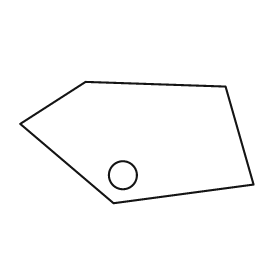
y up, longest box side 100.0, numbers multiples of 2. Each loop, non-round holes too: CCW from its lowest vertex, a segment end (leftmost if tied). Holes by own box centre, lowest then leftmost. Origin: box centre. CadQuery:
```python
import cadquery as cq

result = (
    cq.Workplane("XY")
    .moveTo(-10.0, -26.0)
    .lineTo(50.0, -18.0)
    .lineTo(38.0, 24.0)
    .lineTo(-22.0, 26.0)
    .lineTo(-50.0, 8.0)
    .close()
    .moveTo(-6.0, -14.0)
    .circle(6.0)
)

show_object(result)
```